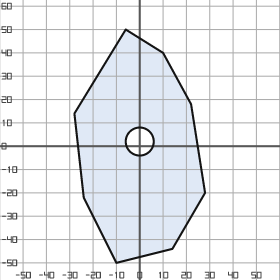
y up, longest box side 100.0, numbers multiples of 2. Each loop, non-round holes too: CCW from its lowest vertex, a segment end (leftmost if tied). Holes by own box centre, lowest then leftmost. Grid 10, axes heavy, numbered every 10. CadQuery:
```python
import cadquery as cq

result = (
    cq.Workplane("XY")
    .moveTo(-10.0, -50.0)
    .lineTo(14.0, -44.0)
    .lineTo(28.0, -20.0)
    .lineTo(22.0, 18.0)
    .lineTo(10.0, 40.0)
    .lineTo(-6.0, 50.0)
    .lineTo(-28.0, 14.0)
    .lineTo(-24.0, -22.0)
    .close()
    .moveTo(0.0, 2.0)
    .circle(6.0)
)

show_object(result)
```